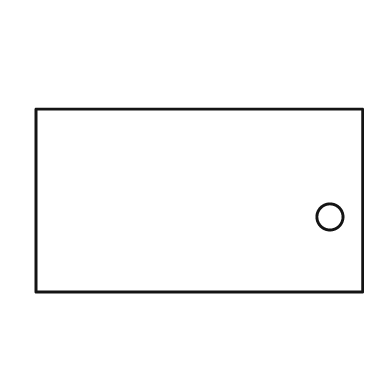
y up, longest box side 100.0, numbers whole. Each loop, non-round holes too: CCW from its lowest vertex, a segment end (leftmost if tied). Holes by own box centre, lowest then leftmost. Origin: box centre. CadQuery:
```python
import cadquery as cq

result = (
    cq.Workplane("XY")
    .moveTo(-50.0, -28.0)
    .lineTo(50.0, -28.0)
    .lineTo(50.0, 28.0)
    .lineTo(-50.0, 28.0)
    .close()
    .moveTo(40.0, -5.0)
    .circle(4.0)
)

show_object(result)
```